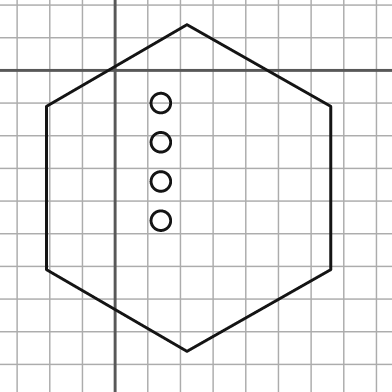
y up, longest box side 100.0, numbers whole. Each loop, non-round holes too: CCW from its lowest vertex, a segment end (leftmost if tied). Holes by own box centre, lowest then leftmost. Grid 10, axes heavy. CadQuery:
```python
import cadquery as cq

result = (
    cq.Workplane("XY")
    .moveTo(22.0, -86.0)
    .lineTo(66.0, -61.0)
    .lineTo(66.0, -11.0)
    .lineTo(22.0, 14.0)
    .lineTo(-21.0, -11.0)
    .lineTo(-21.0, -61.0)
    .close()
    .moveTo(14.0, -46.0)
    .circle(3.0)
    .moveTo(14.0, -34.0)
    .circle(3.0)
    .moveTo(14.0, -22.0)
    .circle(3.0)
    .moveTo(14.0, -10.0)
    .circle(3.0)
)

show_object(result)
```